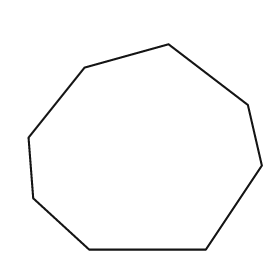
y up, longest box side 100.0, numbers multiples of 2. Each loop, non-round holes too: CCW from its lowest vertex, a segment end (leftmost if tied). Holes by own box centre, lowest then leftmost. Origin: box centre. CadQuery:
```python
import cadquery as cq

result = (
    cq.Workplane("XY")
    .moveTo(-24.0, -44.0)
    .lineTo(26.0, -44.0)
    .lineTo(50.0, -8.0)
    .lineTo(44.0, 18.0)
    .lineTo(10.0, 44.0)
    .lineTo(-26.0, 34.0)
    .lineTo(-50.0, 4.0)
    .lineTo(-48.0, -22.0)
    .close()
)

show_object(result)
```